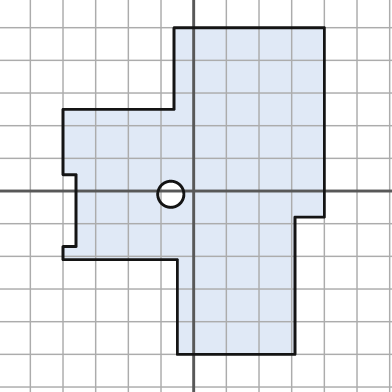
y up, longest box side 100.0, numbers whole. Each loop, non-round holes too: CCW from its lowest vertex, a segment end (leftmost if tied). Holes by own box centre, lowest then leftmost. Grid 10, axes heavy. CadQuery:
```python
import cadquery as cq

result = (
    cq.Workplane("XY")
    .moveTo(-5.0, -50.0)
    .lineTo(31.0, -50.0)
    .lineTo(31.0, -8.0)
    .lineTo(40.0, -8.0)
    .lineTo(40.0, 50.0)
    .lineTo(-6.0, 50.0)
    .lineTo(-6.0, 25.0)
    .lineTo(-40.0, 25.0)
    .lineTo(-40.0, 5.0)
    .lineTo(-36.0, 5.0)
    .lineTo(-36.0, -17.0)
    .lineTo(-40.0, -17.0)
    .lineTo(-40.0, -21.0)
    .lineTo(-5.0, -21.0)
    .close()
    .moveTo(-7.0, -1.0)
    .circle(4.0)
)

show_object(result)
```